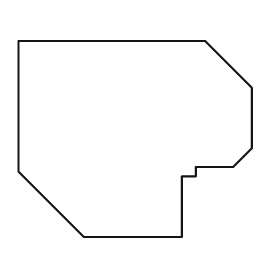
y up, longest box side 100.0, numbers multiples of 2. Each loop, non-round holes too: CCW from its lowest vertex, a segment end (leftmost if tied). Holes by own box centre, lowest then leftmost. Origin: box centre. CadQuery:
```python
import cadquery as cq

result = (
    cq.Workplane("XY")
    .moveTo(-22.0, -42.0)
    .lineTo(20.0, -42.0)
    .lineTo(20.0, -16.0)
    .lineTo(26.0, -16.0)
    .lineTo(26.0, -12.0)
    .lineTo(42.0, -12.0)
    .lineTo(50.0, -4.0)
    .lineTo(50.0, 22.0)
    .lineTo(30.0, 42.0)
    .lineTo(-50.0, 42.0)
    .lineTo(-50.0, -14.0)
    .close()
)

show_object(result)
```